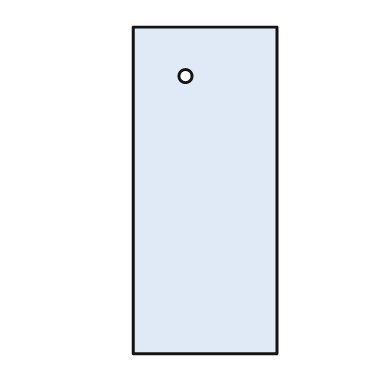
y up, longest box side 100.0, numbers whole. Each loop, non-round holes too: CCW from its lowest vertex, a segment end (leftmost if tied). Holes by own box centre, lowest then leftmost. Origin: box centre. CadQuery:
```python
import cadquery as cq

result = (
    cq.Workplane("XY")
    .moveTo(-22.0, -50.0)
    .lineTo(22.0, -50.0)
    .lineTo(22.0, 50.0)
    .lineTo(-22.0, 50.0)
    .close()
    .moveTo(-6.0, 35.0)
    .circle(2.0)
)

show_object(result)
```